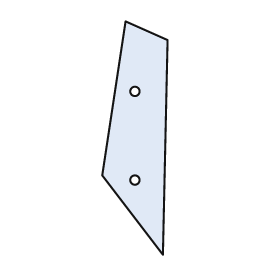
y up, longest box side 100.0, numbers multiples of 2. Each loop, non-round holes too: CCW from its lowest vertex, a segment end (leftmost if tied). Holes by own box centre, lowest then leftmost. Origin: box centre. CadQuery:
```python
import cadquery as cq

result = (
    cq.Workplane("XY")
    .moveTo(12.0, -50.0)
    .lineTo(14.0, 42.0)
    .lineTo(-4.0, 50.0)
    .lineTo(-14.0, -16.0)
    .close()
    .moveTo(0.0, -18.0)
    .circle(2.0)
    .moveTo(0.0, 20.0)
    .circle(2.0)
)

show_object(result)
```